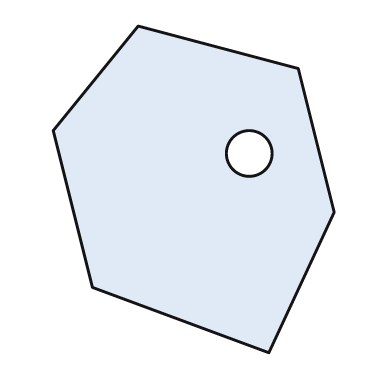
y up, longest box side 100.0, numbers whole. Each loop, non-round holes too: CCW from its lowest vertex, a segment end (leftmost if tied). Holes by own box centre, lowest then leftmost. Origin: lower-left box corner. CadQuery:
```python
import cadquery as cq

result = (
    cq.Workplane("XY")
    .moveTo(66.0, 0.0)
    .lineTo(86.0, 43.0)
    .lineTo(75.0, 87.0)
    .lineTo(26.0, 100.0)
    .lineTo(0.0, 68.0)
    .lineTo(12.0, 20.0)
    .close()
    .moveTo(60.0, 61.0)
    .circle(7.0)
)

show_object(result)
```